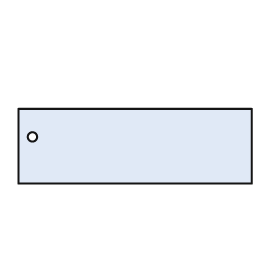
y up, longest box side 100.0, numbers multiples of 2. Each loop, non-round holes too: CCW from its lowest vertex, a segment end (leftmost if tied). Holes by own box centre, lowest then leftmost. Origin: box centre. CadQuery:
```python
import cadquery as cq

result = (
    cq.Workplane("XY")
    .moveTo(-50.0, -16.0)
    .lineTo(50.0, -16.0)
    .lineTo(50.0, 16.0)
    .lineTo(-50.0, 16.0)
    .close()
    .moveTo(-44.0, 4.0)
    .circle(2.0)
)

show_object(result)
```